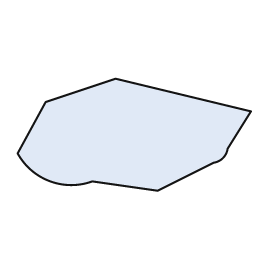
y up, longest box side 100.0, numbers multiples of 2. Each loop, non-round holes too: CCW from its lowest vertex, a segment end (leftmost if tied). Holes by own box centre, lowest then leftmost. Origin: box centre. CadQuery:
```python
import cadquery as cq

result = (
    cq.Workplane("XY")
    .moveTo(10.0, -24.0)
    .lineTo(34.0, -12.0)
    .threePointArc((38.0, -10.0), (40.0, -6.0))
    .lineTo(50.0, 10.0)
    .lineTo(-8.0, 24.0)
    .lineTo(-38.0, 14.0)
    .lineTo(-50.0, -8.0)
    .threePointArc((-36.0, -20.0), (-18.0, -20.0))
    .close()
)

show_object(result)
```